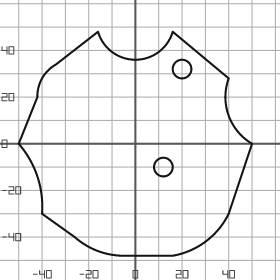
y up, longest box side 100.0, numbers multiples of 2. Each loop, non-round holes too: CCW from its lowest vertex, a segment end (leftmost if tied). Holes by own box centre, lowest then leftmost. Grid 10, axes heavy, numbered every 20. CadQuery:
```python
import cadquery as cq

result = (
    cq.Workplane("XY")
    .moveTo(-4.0, -48.0)
    .lineTo(16.0, -48.0)
    .threePointArc((30.0, -42.0), (40.0, -30.0))
    .lineTo(50.0, 0.0)
    .threePointArc((40.0, 12.0), (40.0, 28.0))
    .lineTo(16.0, 48.0)
    .threePointArc((0.0, 36.0), (-16.0, 48.0))
    .lineTo(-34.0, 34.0)
    .threePointArc((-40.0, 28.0), (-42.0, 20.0))
    .lineTo(-50.0, 0.0)
    .threePointArc((-42.0, -14.0), (-40.0, -30.0))
    .lineTo(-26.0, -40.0)
    .threePointArc((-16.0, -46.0), (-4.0, -48.0))
    .close()
    .moveTo(12.0, -10.0)
    .circle(4.0)
    .moveTo(20.0, 32.0)
    .circle(4.0)
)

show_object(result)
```